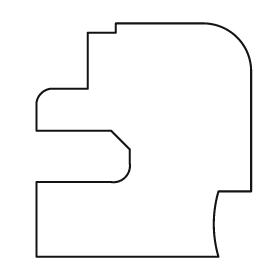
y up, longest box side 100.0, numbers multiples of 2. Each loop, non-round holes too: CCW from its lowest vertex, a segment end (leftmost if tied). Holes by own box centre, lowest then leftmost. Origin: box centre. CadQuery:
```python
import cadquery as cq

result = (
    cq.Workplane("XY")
    .moveTo(-46.0, -50.0)
    .lineTo(32.0, -50.0)
    .threePointArc((30.0, -36.0), (32.0, -22.0))
    .lineTo(46.0, -22.0)
    .lineTo(46.0, 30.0)
    .threePointArc((40.0, 44.0), (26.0, 50.0))
    .lineTo(-12.0, 50.0)
    .lineTo(-12.0, 46.0)
    .lineTo(-24.0, 46.0)
    .lineTo(-24.0, 22.0)
    .lineTo(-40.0, 22.0)
    .threePointArc((-44.0, 20.0), (-46.0, 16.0))
    .lineTo(-46.0, 4.0)
    .lineTo(-14.0, 4.0)
    .lineTo(-6.0, -4.0)
    .lineTo(-6.0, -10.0)
    .threePointArc((-8.0, -16.0), (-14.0, -18.0))
    .lineTo(-46.0, -18.0)
    .close()
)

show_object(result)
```